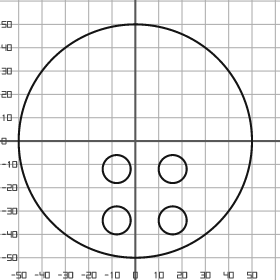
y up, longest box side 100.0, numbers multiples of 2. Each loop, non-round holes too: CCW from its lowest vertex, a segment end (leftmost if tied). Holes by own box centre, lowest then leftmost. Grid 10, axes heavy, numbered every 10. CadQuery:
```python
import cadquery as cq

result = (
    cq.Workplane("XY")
    .moveTo(0.0, 0.0)
    .circle(50.0)
    .moveTo(-8.0, -34.0)
    .circle(6.0)
    .moveTo(16.0, -34.0)
    .circle(6.0)
    .moveTo(-8.0, -12.0)
    .circle(6.0)
    .moveTo(16.0, -12.0)
    .circle(6.0)
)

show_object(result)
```